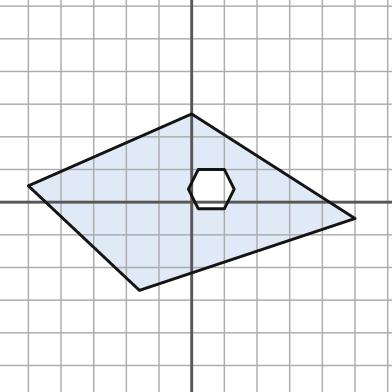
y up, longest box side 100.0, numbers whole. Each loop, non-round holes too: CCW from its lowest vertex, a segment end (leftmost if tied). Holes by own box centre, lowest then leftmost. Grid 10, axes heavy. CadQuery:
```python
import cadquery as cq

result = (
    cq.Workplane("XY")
    .moveTo(-16.0, -27.0)
    .lineTo(50.0, -5.0)
    .lineTo(0.0, 27.0)
    .lineTo(-50.0, 5.0)
    .close()
    .moveTo(2.0, -2.0)
    .lineTo(10.0, -2.0)
    .lineTo(13.0, 4.0)
    .lineTo(10.0, 10.0)
    .lineTo(2.0, 10.0)
    .lineTo(-1.0, 4.0)
    .close()
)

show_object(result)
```